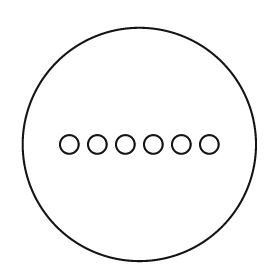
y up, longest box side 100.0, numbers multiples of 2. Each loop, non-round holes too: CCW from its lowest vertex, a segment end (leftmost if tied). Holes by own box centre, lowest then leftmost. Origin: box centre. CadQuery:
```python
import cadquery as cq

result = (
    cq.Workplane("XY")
    .moveTo(0.0, 0.0)
    .circle(50.0)
    .moveTo(-30.0, 0.0)
    .circle(4.0)
    .moveTo(-18.0, 0.0)
    .circle(4.0)
    .moveTo(-6.0, 0.0)
    .circle(4.0)
    .moveTo(6.0, 0.0)
    .circle(4.0)
    .moveTo(18.0, 0.0)
    .circle(4.0)
    .moveTo(30.0, 0.0)
    .circle(4.0)
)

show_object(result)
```